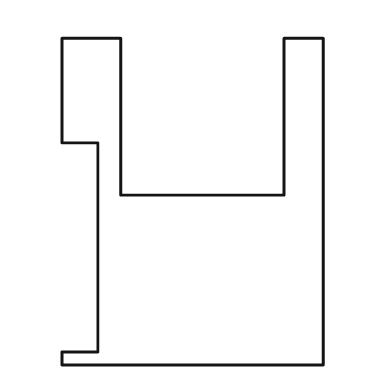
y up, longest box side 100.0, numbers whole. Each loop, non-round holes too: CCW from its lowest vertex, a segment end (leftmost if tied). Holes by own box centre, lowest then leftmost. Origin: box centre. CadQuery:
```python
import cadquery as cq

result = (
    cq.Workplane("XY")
    .moveTo(-40.0, -50.0)
    .lineTo(40.0, -50.0)
    .lineTo(40.0, 50.0)
    .lineTo(28.0, 50.0)
    .lineTo(28.0, 2.0)
    .lineTo(-22.0, 2.0)
    .lineTo(-22.0, 50.0)
    .lineTo(-40.0, 50.0)
    .lineTo(-40.0, 18.0)
    .lineTo(-29.0, 18.0)
    .lineTo(-29.0, -46.0)
    .lineTo(-40.0, -46.0)
    .close()
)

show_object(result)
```